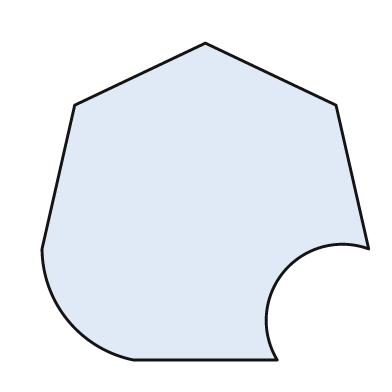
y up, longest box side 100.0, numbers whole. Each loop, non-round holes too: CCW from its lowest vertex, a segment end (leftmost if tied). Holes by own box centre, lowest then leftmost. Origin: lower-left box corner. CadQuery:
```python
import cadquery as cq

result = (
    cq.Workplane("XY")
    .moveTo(28.0, 0.0)
    .lineTo(72.0, 0.0)
    .threePointArc((74.0, 27.0), (100.0, 34.0))
    .lineTo(90.0, 78.0)
    .lineTo(50.0, 97.0)
    .lineTo(10.0, 78.0)
    .lineTo(0.0, 34.0)
    .threePointArc((8.0, 12.0), (28.0, 0.0))
    .close()
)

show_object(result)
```